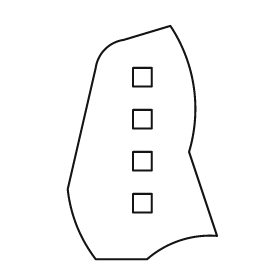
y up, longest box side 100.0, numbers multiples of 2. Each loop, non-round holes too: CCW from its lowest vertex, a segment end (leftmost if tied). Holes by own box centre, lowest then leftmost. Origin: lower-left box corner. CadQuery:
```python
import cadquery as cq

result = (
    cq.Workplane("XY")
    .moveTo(12.0, 0.0)
    .lineTo(34.0, 0.0)
    .threePointArc((48.0, 8.0), (64.0, 10.0))
    .lineTo(52.0, 46.0)
    .threePointArc((54.0, 74.0), (44.0, 100.0))
    .lineTo(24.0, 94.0)
    .threePointArc((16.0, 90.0), (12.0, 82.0))
    .lineTo(0.0, 30.0)
    .threePointArc((4.0, 14.0), (12.0, 0.0))
    .close()
    .moveTo(28.0, 20.0)
    .lineTo(36.0, 20.0)
    .lineTo(36.0, 28.0)
    .lineTo(28.0, 28.0)
    .close()
    .moveTo(28.0, 38.0)
    .lineTo(36.0, 38.0)
    .lineTo(36.0, 46.0)
    .lineTo(28.0, 46.0)
    .close()
    .moveTo(28.0, 56.0)
    .lineTo(36.0, 56.0)
    .lineTo(36.0, 64.0)
    .lineTo(28.0, 64.0)
    .close()
    .moveTo(28.0, 74.0)
    .lineTo(36.0, 74.0)
    .lineTo(36.0, 82.0)
    .lineTo(28.0, 82.0)
    .close()
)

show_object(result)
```